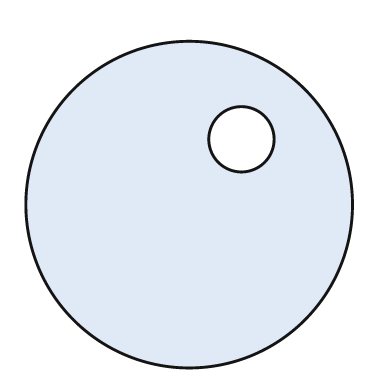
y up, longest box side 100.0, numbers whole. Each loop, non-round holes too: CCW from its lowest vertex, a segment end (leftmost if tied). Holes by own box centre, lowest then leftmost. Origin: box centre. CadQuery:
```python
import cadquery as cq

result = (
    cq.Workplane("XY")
    .moveTo(0.0, 0.0)
    .circle(50.0)
    .moveTo(16.0, 20.0)
    .circle(10.0)
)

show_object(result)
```